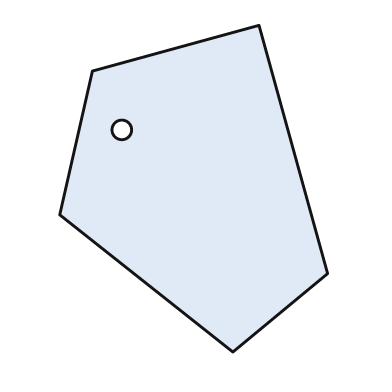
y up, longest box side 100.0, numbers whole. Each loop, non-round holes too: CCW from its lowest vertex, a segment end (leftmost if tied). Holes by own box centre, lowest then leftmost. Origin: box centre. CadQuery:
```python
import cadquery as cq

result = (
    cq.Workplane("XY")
    .moveTo(12.0, -50.0)
    .lineTo(41.0, -26.0)
    .lineTo(20.0, 50.0)
    .lineTo(-31.0, 36.0)
    .lineTo(-41.0, -8.0)
    .close()
    .moveTo(-22.0, 18.0)
    .circle(3.0)
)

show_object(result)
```